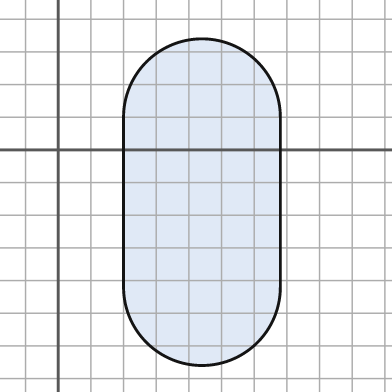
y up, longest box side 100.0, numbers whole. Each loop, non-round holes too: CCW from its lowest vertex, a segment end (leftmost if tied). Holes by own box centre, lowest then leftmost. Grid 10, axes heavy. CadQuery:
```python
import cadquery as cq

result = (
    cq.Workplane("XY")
    .moveTo(20.0, -42.0)
    .threePointArc((44.0, -66.0), (68.0, -42.0))
    .lineTo(68.0, 10.0)
    .threePointArc((44.0, 34.0), (20.0, 10.0))
    .close()
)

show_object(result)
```